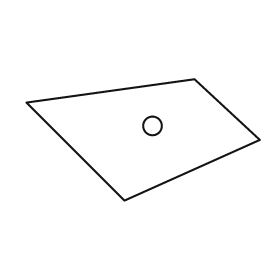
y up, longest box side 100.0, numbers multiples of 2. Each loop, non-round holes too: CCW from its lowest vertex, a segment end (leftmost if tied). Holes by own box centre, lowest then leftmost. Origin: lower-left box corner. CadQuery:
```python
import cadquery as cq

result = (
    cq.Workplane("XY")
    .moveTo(42.0, 0.0)
    .lineTo(100.0, 26.0)
    .lineTo(72.0, 52.0)
    .lineTo(0.0, 42.0)
    .close()
    .moveTo(54.0, 32.0)
    .circle(4.0)
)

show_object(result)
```